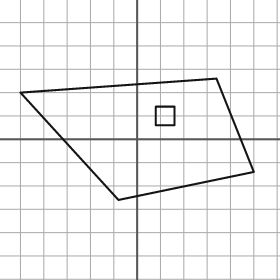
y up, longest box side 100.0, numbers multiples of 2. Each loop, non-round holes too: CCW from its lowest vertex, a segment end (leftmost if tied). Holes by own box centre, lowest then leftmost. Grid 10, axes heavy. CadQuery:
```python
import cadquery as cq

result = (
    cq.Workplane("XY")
    .moveTo(-8.0, -26.0)
    .lineTo(50.0, -14.0)
    .lineTo(34.0, 26.0)
    .lineTo(-50.0, 20.0)
    .close()
    .moveTo(8.0, 6.0)
    .lineTo(16.0, 6.0)
    .lineTo(16.0, 14.0)
    .lineTo(8.0, 14.0)
    .close()
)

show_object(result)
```